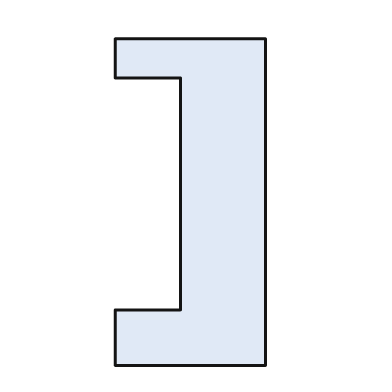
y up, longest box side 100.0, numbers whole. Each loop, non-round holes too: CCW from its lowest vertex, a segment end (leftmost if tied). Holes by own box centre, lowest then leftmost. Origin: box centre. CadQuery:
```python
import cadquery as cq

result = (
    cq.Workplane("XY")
    .moveTo(-23.0, -50.0)
    .lineTo(23.0, -50.0)
    .lineTo(23.0, 50.0)
    .lineTo(-23.0, 50.0)
    .lineTo(-23.0, 38.0)
    .lineTo(-3.0, 38.0)
    .lineTo(-3.0, -33.0)
    .lineTo(-23.0, -33.0)
    .close()
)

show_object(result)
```